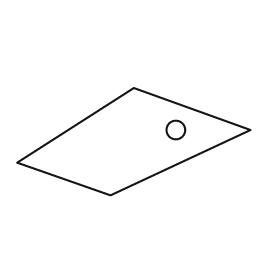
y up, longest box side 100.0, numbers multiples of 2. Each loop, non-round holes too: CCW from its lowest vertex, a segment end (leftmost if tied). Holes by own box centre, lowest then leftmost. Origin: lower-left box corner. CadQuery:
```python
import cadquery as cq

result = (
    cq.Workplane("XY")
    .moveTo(40.0, 0.0)
    .lineTo(100.0, 28.0)
    .lineTo(50.0, 46.0)
    .lineTo(0.0, 14.0)
    .close()
    .moveTo(68.0, 28.0)
    .circle(4.0)
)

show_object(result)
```